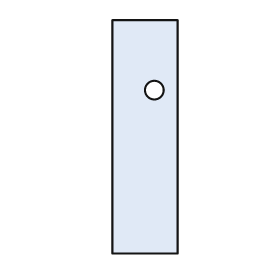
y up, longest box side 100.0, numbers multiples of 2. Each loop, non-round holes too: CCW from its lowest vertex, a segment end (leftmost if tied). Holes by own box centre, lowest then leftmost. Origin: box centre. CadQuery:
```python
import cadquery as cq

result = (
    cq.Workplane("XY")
    .moveTo(-14.0, -50.0)
    .lineTo(14.0, -50.0)
    .lineTo(14.0, 50.0)
    .lineTo(-14.0, 50.0)
    .close()
    .moveTo(4.0, 20.0)
    .circle(4.0)
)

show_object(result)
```